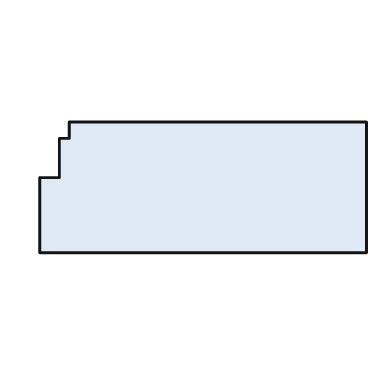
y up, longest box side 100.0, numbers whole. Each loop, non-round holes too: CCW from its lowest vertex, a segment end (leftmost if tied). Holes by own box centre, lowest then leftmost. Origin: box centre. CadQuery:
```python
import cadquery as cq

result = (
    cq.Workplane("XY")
    .moveTo(-50.0, -20.0)
    .lineTo(50.0, -20.0)
    .lineTo(50.0, 20.0)
    .lineTo(-41.0, 20.0)
    .lineTo(-41.0, 15.0)
    .lineTo(-44.0, 15.0)
    .lineTo(-44.0, 3.0)
    .lineTo(-50.0, 3.0)
    .close()
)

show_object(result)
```